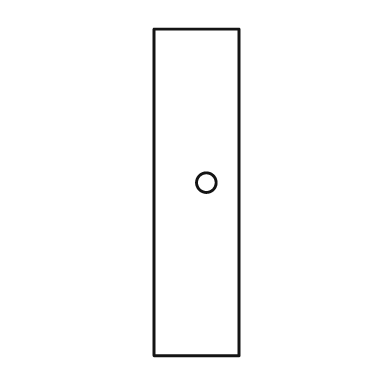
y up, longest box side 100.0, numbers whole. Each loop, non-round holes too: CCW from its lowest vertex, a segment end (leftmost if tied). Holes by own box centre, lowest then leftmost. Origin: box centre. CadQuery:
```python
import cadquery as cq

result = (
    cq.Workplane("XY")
    .moveTo(-13.0, -50.0)
    .lineTo(13.0, -50.0)
    .lineTo(13.0, 50.0)
    .lineTo(-13.0, 50.0)
    .close()
    .moveTo(3.0, 3.0)
    .circle(3.0)
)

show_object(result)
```